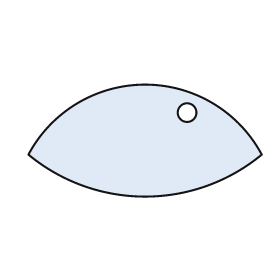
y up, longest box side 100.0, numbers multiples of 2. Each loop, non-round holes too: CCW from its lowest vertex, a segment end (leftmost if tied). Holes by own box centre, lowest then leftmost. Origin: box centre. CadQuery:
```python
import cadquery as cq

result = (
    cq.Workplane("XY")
    .moveTo(-50.0, -6.0)
    .threePointArc((0.0, -24.0), (50.0, -6.0))
    .threePointArc((0.0, 24.0), (-50.0, -6.0))
    .close()
    .moveTo(18.0, 12.0)
    .circle(4.0)
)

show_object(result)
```